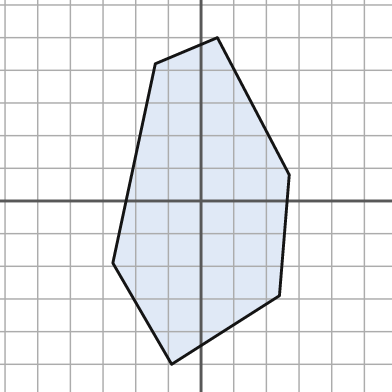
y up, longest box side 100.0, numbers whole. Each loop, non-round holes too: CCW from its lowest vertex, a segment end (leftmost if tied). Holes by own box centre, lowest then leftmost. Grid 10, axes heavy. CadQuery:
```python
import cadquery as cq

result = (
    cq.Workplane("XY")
    .moveTo(-9.0, -50.0)
    .lineTo(24.0, -29.0)
    .lineTo(27.0, 8.0)
    .lineTo(5.0, 50.0)
    .lineTo(-14.0, 42.0)
    .lineTo(-27.0, -19.0)
    .close()
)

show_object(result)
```